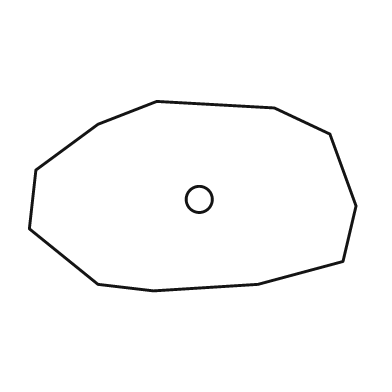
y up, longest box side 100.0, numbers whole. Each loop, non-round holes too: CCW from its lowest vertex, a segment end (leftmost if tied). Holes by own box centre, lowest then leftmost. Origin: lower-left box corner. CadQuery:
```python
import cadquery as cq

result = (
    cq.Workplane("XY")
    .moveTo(38.0, 0.0)
    .lineTo(70.0, 2.0)
    .lineTo(96.0, 9.0)
    .lineTo(100.0, 26.0)
    .lineTo(92.0, 48.0)
    .lineTo(75.0, 56.0)
    .lineTo(39.0, 58.0)
    .lineTo(21.0, 51.0)
    .lineTo(2.0, 37.0)
    .lineTo(0.0, 19.0)
    .lineTo(21.0, 2.0)
    .close()
    .moveTo(52.0, 28.0)
    .circle(4.0)
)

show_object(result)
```